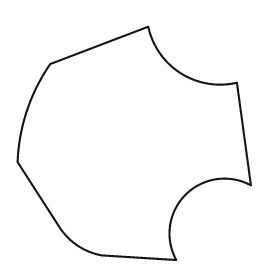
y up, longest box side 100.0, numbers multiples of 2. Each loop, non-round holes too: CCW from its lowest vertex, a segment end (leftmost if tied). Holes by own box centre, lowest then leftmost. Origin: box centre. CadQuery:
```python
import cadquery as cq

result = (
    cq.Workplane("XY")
    .moveTo(18.0, -50.0)
    .threePointArc((22.0, -22.0), (50.0, -18.0))
    .lineTo(44.0, 26.0)
    .threePointArc((20.0, 30.0), (6.0, 50.0))
    .lineTo(-36.0, 34.0)
    .threePointArc((-46.0, 14.0), (-50.0, -8.0))
    .lineTo(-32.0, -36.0)
    .threePointArc((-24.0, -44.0), (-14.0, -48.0))
    .close()
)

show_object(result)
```